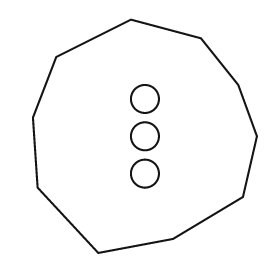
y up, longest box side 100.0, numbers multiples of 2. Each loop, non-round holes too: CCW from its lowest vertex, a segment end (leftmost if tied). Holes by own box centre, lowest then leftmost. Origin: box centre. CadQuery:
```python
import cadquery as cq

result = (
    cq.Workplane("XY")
    .moveTo(-20.0, -50.0)
    .lineTo(12.0, -44.0)
    .lineTo(42.0, -26.0)
    .lineTo(48.0, 0.0)
    .lineTo(40.0, 22.0)
    .lineTo(24.0, 42.0)
    .lineTo(-6.0, 50.0)
    .lineTo(-38.0, 34.0)
    .lineTo(-48.0, 8.0)
    .lineTo(-46.0, -22.0)
    .close()
    .moveTo(0.0, -16.0)
    .circle(6.0)
    .moveTo(0.0, 0.0)
    .circle(6.0)
    .moveTo(0.0, 16.0)
    .circle(6.0)
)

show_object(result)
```